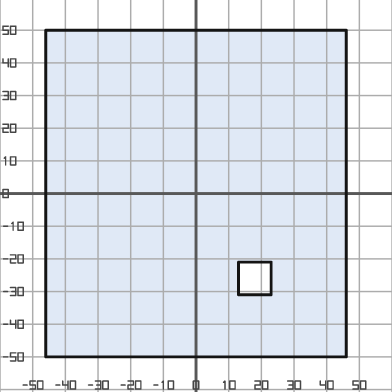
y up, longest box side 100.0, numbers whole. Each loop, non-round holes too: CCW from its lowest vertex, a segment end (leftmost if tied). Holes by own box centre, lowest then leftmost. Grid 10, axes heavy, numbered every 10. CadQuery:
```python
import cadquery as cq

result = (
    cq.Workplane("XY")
    .moveTo(-46.0, -50.0)
    .lineTo(46.0, -50.0)
    .lineTo(46.0, 50.0)
    .lineTo(-46.0, 50.0)
    .close()
    .moveTo(13.0, -31.0)
    .lineTo(23.0, -31.0)
    .lineTo(23.0, -21.0)
    .lineTo(13.0, -21.0)
    .close()
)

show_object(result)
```